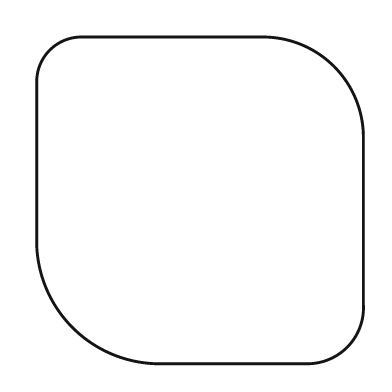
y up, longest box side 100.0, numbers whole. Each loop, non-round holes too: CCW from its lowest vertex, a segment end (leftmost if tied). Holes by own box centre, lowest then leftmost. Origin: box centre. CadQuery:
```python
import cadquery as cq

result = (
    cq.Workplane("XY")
    .moveTo(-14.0, -50.0)
    .lineTo(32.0, -50.0)
    .threePointArc((45.0, -45.0), (50.0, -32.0))
    .lineTo(50.0, 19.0)
    .threePointArc((41.0, 41.0), (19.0, 50.0))
    .lineTo(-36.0, 50.0)
    .threePointArc((-46.0, 46.0), (-50.0, 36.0))
    .lineTo(-50.0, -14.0)
    .threePointArc((-39.0, -39.0), (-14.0, -50.0))
    .close()
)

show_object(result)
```